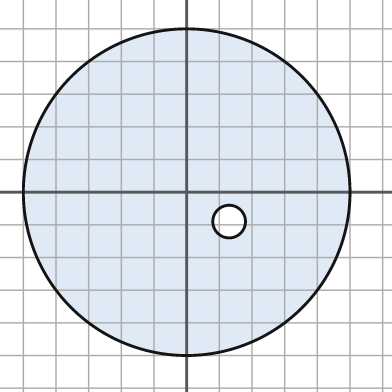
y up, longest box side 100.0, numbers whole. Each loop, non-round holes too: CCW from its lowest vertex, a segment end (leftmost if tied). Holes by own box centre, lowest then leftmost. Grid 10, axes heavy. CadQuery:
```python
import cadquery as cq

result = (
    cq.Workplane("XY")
    .moveTo(0.0, 0.0)
    .circle(50.0)
    .moveTo(13.0, -9.0)
    .circle(5.0)
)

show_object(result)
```